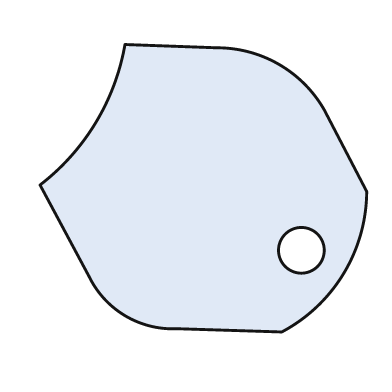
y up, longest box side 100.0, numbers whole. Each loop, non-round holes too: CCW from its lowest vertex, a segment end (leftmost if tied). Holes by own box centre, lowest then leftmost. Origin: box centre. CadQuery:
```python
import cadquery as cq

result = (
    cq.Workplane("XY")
    .moveTo(24.0, -44.0)
    .threePointArc((43.0, -26.0), (50.0, -1.0))
    .lineTo(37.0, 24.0)
    .threePointArc((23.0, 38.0), (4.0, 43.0))
    .lineTo(-24.0, 44.0)
    .threePointArc((-33.0, 20.0), (-50.0, 1.0))
    .lineTo(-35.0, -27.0)
    .threePointArc((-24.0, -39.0), (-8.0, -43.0))
    .close()
    .moveTo(30.0, -19.0)
    .circle(7.0)
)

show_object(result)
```